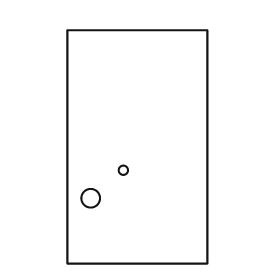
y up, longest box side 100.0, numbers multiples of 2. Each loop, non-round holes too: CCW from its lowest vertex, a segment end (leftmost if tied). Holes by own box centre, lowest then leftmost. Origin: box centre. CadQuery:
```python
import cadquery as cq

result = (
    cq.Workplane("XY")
    .moveTo(-30.0, -50.0)
    .lineTo(30.0, -50.0)
    .lineTo(30.0, 50.0)
    .lineTo(-30.0, 50.0)
    .close()
    .moveTo(-20.0, -22.0)
    .circle(4.0)
    .moveTo(-6.0, -10.0)
    .circle(2.0)
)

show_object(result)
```